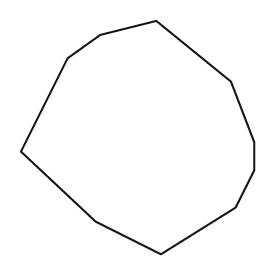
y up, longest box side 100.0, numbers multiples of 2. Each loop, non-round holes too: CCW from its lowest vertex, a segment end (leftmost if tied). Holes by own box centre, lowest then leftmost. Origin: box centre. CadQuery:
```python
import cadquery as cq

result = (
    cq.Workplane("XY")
    .moveTo(10.0, -50.0)
    .lineTo(42.0, -30.0)
    .lineTo(50.0, -14.0)
    .lineTo(50.0, -2.0)
    .lineTo(40.0, 24.0)
    .lineTo(8.0, 50.0)
    .lineTo(-16.0, 44.0)
    .lineTo(-30.0, 34.0)
    .lineTo(-50.0, -6.0)
    .lineTo(-18.0, -36.0)
    .close()
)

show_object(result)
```